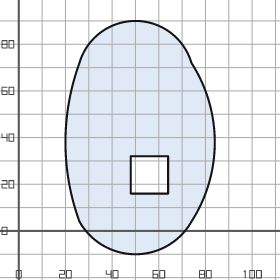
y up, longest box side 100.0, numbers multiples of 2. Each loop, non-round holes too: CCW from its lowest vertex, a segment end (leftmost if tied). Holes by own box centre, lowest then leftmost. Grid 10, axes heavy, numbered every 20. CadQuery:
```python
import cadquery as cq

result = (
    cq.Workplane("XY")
    .moveTo(26.0, 4.0)
    .threePointArc((50.0, -10.0), (74.0, 4.0))
    .threePointArc((84.0, 38.0), (74.0, 72.0))
    .threePointArc((50.0, 90.0), (26.0, 72.0))
    .threePointArc((20.0, 38.0), (26.0, 4.0))
    .close()
    .moveTo(48.0, 16.0)
    .lineTo(64.0, 16.0)
    .lineTo(64.0, 32.0)
    .lineTo(48.0, 32.0)
    .close()
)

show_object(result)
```